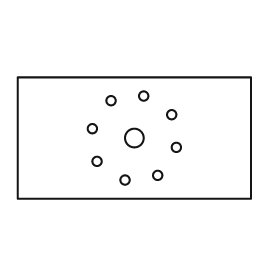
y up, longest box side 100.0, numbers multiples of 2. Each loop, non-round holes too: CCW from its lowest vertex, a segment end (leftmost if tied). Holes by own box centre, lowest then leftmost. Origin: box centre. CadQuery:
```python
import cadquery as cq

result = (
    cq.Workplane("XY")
    .moveTo(-50.0, -26.0)
    .lineTo(50.0, -26.0)
    .lineTo(50.0, 26.0)
    .lineTo(-50.0, 26.0)
    .close()
    .moveTo(-4.0, -18.0)
    .circle(2.0)
    .moveTo(10.0, -16.0)
    .circle(2.0)
    .moveTo(-16.0, -10.0)
    .circle(2.0)
    .moveTo(18.0, -4.0)
    .circle(2.0)
    .moveTo(0.0, 0.0)
    .circle(4.0)
    .moveTo(-18.0, 4.0)
    .circle(2.0)
    .moveTo(16.0, 10.0)
    .circle(2.0)
    .moveTo(-10.0, 16.0)
    .circle(2.0)
    .moveTo(4.0, 18.0)
    .circle(2.0)
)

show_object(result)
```